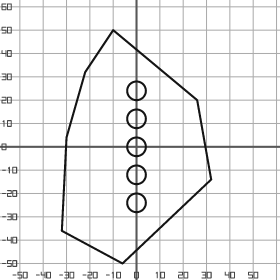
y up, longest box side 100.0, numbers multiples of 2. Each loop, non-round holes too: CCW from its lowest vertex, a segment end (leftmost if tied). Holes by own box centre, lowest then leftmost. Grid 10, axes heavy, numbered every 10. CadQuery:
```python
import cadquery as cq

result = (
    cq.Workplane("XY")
    .moveTo(-6.0, -50.0)
    .lineTo(32.0, -14.0)
    .lineTo(26.0, 20.0)
    .lineTo(-10.0, 50.0)
    .lineTo(-22.0, 32.0)
    .lineTo(-30.0, 4.0)
    .lineTo(-32.0, -36.0)
    .close()
    .moveTo(0.0, -24.0)
    .circle(4.0)
    .moveTo(0.0, -12.0)
    .circle(4.0)
    .moveTo(0.0, 0.0)
    .circle(4.0)
    .moveTo(0.0, 12.0)
    .circle(4.0)
    .moveTo(0.0, 24.0)
    .circle(4.0)
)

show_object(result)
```